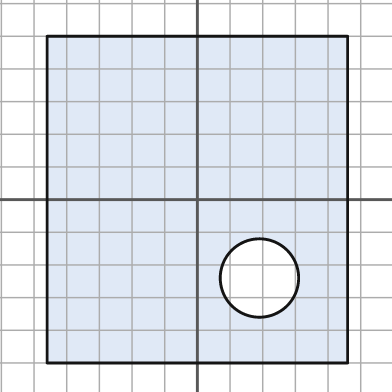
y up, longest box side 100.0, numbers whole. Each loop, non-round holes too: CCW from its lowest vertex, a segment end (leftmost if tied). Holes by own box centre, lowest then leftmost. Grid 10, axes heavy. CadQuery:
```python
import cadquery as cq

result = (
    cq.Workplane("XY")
    .moveTo(-46.0, -50.0)
    .lineTo(46.0, -50.0)
    .lineTo(46.0, 50.0)
    .lineTo(-46.0, 50.0)
    .close()
    .moveTo(19.0, -24.0)
    .circle(12.0)
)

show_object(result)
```